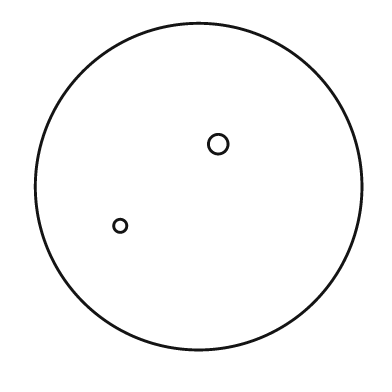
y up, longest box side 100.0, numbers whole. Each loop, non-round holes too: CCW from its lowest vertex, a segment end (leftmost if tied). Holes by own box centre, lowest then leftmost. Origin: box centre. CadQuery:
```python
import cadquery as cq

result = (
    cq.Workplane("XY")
    .moveTo(0.0, 0.0)
    .circle(50.0)
    .moveTo(-24.0, -12.0)
    .circle(2.0)
    .moveTo(6.0, 13.0)
    .circle(3.0)
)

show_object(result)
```